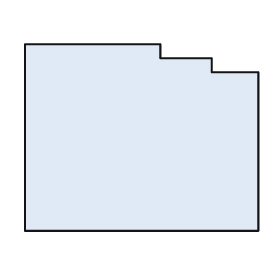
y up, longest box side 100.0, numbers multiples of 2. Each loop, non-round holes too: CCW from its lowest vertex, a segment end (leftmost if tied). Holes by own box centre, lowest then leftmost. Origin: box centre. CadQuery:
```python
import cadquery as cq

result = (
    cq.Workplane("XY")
    .moveTo(-50.0, -40.0)
    .lineTo(50.0, -40.0)
    .lineTo(50.0, 28.0)
    .lineTo(30.0, 28.0)
    .lineTo(30.0, 34.0)
    .lineTo(8.0, 34.0)
    .lineTo(8.0, 40.0)
    .lineTo(-50.0, 40.0)
    .close()
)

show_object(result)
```